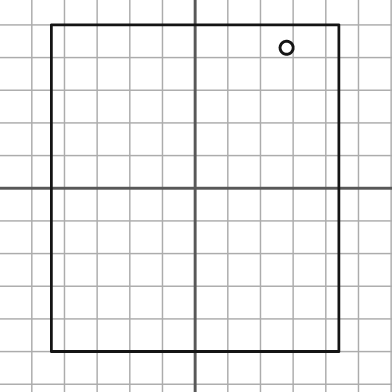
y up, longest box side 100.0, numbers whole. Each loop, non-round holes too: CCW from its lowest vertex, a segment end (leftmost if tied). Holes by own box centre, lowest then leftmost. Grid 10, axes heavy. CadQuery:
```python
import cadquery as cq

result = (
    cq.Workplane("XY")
    .moveTo(-44.0, -50.0)
    .lineTo(44.0, -50.0)
    .lineTo(44.0, 50.0)
    .lineTo(-44.0, 50.0)
    .close()
    .moveTo(28.0, 43.0)
    .circle(2.0)
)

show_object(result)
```